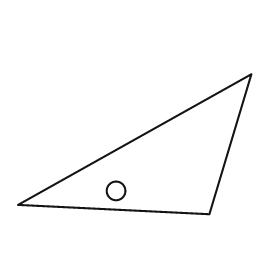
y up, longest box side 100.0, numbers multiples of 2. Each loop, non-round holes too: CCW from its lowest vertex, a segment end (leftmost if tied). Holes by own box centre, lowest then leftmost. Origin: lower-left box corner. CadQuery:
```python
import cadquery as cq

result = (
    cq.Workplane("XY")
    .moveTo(82.0, 0.0)
    .lineTo(100.0, 60.0)
    .lineTo(0.0, 4.0)
    .close()
    .moveTo(42.0, 10.0)
    .circle(4.0)
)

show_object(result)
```